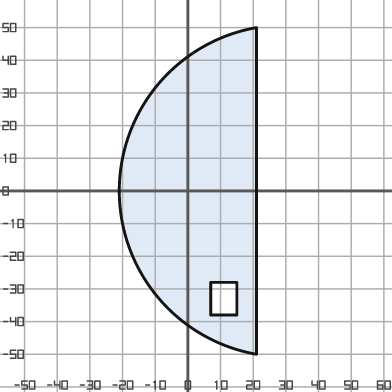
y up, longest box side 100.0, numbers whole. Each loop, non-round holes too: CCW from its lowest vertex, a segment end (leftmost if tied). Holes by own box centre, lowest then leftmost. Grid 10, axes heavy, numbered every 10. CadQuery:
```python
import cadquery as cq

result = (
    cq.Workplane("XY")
    .moveTo(21.0, -50.0)
    .lineTo(21.0, 50.0)
    .threePointArc((-21.0, 0.0), (21.0, -50.0))
    .close()
    .moveTo(7.0, -38.0)
    .lineTo(15.0, -38.0)
    .lineTo(15.0, -28.0)
    .lineTo(7.0, -28.0)
    .close()
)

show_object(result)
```